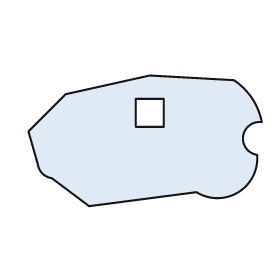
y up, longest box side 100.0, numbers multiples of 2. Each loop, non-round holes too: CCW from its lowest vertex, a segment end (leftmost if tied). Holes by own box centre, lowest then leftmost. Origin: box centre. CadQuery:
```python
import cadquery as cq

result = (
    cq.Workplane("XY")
    .moveTo(-24.0, -28.0)
    .lineTo(22.0, -22.0)
    .threePointArc((40.0, -22.0), (48.0, -6.0))
    .threePointArc((42.0, 2.0), (50.0, 8.0))
    .threePointArc((46.0, 18.0), (38.0, 26.0))
    .lineTo(2.0, 28.0)
    .lineTo(-34.0, 20.0)
    .lineTo(-50.0, 4.0)
    .lineTo(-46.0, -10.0)
    .threePointArc((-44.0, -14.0), (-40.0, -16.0))
    .close()
    .moveTo(-4.0, 6.0)
    .lineTo(8.0, 6.0)
    .lineTo(8.0, 18.0)
    .lineTo(-4.0, 18.0)
    .close()
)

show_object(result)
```